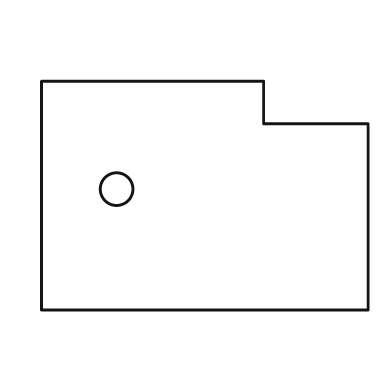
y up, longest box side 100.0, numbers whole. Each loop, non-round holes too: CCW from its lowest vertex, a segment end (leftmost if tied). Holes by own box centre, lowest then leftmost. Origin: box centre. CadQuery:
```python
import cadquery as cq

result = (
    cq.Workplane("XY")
    .moveTo(-50.0, -35.0)
    .lineTo(50.0, -35.0)
    .lineTo(50.0, 22.0)
    .lineTo(18.0, 22.0)
    .lineTo(18.0, 35.0)
    .lineTo(-50.0, 35.0)
    .close()
    .moveTo(-27.0, 2.0)
    .circle(5.0)
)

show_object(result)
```